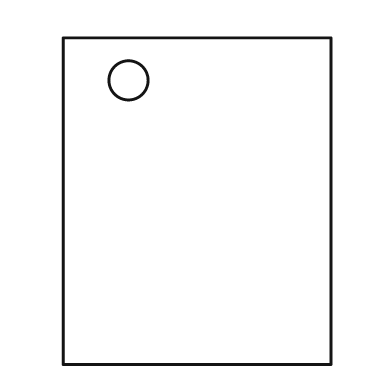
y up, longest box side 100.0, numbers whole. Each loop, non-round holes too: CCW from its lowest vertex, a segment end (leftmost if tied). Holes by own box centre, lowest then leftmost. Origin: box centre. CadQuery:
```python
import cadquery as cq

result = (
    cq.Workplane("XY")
    .moveTo(-41.0, -50.0)
    .lineTo(41.0, -50.0)
    .lineTo(41.0, 50.0)
    .lineTo(-41.0, 50.0)
    .close()
    .moveTo(-21.0, 37.0)
    .circle(6.0)
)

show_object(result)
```